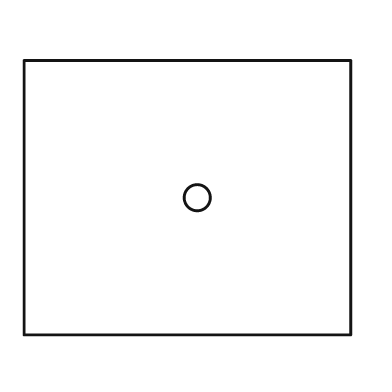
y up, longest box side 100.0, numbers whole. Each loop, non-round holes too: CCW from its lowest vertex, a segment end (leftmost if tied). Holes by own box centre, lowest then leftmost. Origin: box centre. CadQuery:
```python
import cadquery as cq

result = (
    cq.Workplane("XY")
    .moveTo(-50.0, -42.0)
    .lineTo(50.0, -42.0)
    .lineTo(50.0, 42.0)
    .lineTo(-50.0, 42.0)
    .close()
    .moveTo(3.0, 0.0)
    .circle(4.0)
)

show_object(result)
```